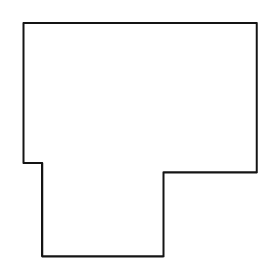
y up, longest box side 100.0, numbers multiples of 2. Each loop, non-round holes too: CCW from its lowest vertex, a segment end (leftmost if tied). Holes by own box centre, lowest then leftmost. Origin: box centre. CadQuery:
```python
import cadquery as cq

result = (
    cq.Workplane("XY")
    .moveTo(-42.0, -50.0)
    .lineTo(10.0, -50.0)
    .lineTo(10.0, -14.0)
    .lineTo(50.0, -14.0)
    .lineTo(50.0, 50.0)
    .lineTo(-50.0, 50.0)
    .lineTo(-50.0, -10.0)
    .lineTo(-42.0, -10.0)
    .close()
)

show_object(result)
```